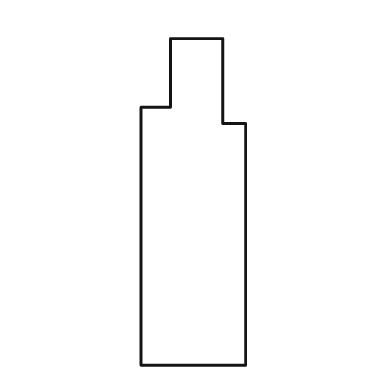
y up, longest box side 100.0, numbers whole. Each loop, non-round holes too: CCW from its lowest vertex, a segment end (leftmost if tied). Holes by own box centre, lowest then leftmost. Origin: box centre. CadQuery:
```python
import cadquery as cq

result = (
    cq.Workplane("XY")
    .moveTo(-16.0, -50.0)
    .lineTo(16.0, -50.0)
    .lineTo(16.0, 24.0)
    .lineTo(9.0, 24.0)
    .lineTo(9.0, 50.0)
    .lineTo(-7.0, 50.0)
    .lineTo(-7.0, 29.0)
    .lineTo(-16.0, 29.0)
    .close()
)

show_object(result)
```